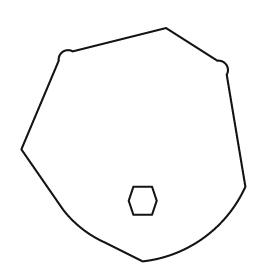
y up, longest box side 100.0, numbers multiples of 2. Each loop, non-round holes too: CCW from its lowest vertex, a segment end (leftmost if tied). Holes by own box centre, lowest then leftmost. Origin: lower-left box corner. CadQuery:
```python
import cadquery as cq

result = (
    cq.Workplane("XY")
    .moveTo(52.0, 0.0)
    .threePointArc((78.0, 10.0), (96.0, 32.0))
    .lineTo(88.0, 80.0)
    .threePointArc((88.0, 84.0), (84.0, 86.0))
    .lineTo(62.0, 100.0)
    .lineTo(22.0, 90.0)
    .threePointArc((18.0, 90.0), (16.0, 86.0))
    .lineTo(0.0, 48.0)
    .lineTo(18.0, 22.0)
    .threePointArc((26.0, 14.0), (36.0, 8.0))
    .close()
    .moveTo(48.0, 20.0)
    .lineTo(56.0, 20.0)
    .lineTo(58.0, 26.0)
    .lineTo(56.0, 32.0)
    .lineTo(48.0, 32.0)
    .lineTo(46.0, 26.0)
    .close()
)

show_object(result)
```